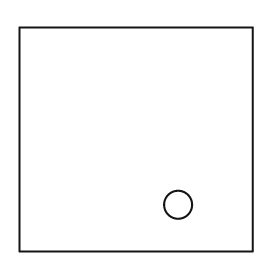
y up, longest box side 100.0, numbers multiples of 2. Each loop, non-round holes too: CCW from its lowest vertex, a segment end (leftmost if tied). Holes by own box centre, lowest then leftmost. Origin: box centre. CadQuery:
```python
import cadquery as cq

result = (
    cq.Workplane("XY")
    .moveTo(-50.0, -48.0)
    .lineTo(50.0, -48.0)
    .lineTo(50.0, 48.0)
    .lineTo(-50.0, 48.0)
    .close()
    .moveTo(18.0, -28.0)
    .circle(6.0)
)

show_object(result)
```